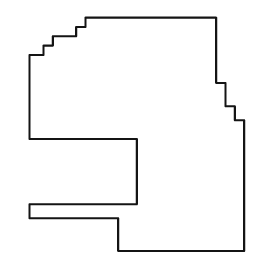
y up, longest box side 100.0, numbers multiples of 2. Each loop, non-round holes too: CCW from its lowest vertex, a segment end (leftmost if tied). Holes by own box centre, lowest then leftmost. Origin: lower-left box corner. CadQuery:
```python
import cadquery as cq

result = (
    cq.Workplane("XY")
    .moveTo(38.0, 0.0)
    .lineTo(92.0, 0.0)
    .lineTo(92.0, 56.0)
    .lineTo(88.0, 56.0)
    .lineTo(88.0, 62.0)
    .lineTo(84.0, 62.0)
    .lineTo(84.0, 72.0)
    .lineTo(80.0, 72.0)
    .lineTo(80.0, 100.0)
    .lineTo(24.0, 100.0)
    .lineTo(24.0, 96.0)
    .lineTo(20.0, 96.0)
    .lineTo(20.0, 92.0)
    .lineTo(10.0, 92.0)
    .lineTo(10.0, 88.0)
    .lineTo(6.0, 88.0)
    .lineTo(6.0, 84.0)
    .lineTo(0.0, 84.0)
    .lineTo(0.0, 48.0)
    .lineTo(46.0, 48.0)
    .lineTo(46.0, 20.0)
    .lineTo(0.0, 20.0)
    .lineTo(0.0, 14.0)
    .lineTo(38.0, 14.0)
    .close()
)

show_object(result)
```